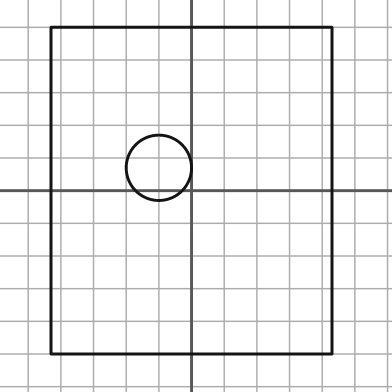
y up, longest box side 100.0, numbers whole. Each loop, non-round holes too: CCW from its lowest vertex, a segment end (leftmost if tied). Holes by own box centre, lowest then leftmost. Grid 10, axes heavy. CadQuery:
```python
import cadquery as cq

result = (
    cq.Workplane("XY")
    .moveTo(-43.0, -50.0)
    .lineTo(43.0, -50.0)
    .lineTo(43.0, 50.0)
    .lineTo(-43.0, 50.0)
    .close()
    .moveTo(-10.0, 7.0)
    .circle(10.0)
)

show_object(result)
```